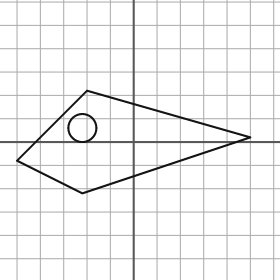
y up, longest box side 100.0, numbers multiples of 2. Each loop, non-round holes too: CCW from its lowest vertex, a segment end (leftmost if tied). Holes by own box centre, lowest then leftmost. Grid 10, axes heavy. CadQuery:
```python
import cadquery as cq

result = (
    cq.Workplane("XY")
    .moveTo(-22.0, -22.0)
    .lineTo(50.0, 2.0)
    .lineTo(-20.0, 22.0)
    .lineTo(-50.0, -8.0)
    .close()
    .moveTo(-22.0, 6.0)
    .circle(6.0)
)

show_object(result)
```